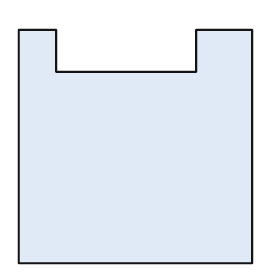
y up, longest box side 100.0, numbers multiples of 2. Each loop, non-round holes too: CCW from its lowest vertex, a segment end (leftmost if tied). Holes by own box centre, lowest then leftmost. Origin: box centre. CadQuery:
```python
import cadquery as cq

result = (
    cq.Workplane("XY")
    .moveTo(-50.0, -50.0)
    .lineTo(50.0, -50.0)
    .lineTo(50.0, 50.0)
    .lineTo(26.0, 50.0)
    .lineTo(26.0, 32.0)
    .lineTo(-34.0, 32.0)
    .lineTo(-34.0, 50.0)
    .lineTo(-50.0, 50.0)
    .close()
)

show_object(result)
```